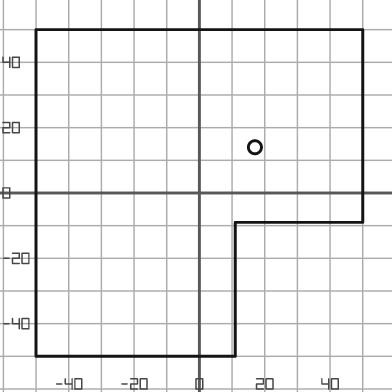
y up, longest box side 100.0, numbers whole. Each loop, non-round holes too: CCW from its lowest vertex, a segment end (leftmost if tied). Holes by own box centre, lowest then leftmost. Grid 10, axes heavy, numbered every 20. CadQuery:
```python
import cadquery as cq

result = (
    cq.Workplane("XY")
    .moveTo(-50.0, -50.0)
    .lineTo(11.0, -50.0)
    .lineTo(11.0, -9.0)
    .lineTo(50.0, -9.0)
    .lineTo(50.0, 50.0)
    .lineTo(-50.0, 50.0)
    .close()
    .moveTo(17.0, 14.0)
    .circle(2.0)
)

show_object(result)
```